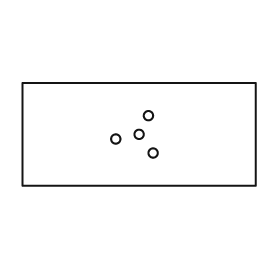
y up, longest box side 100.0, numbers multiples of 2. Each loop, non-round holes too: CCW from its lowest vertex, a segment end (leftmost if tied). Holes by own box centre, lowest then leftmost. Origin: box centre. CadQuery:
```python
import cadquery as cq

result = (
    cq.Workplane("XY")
    .moveTo(-50.0, -22.0)
    .lineTo(50.0, -22.0)
    .lineTo(50.0, 22.0)
    .lineTo(-50.0, 22.0)
    .close()
    .moveTo(6.0, -8.0)
    .circle(2.0)
    .moveTo(-10.0, -2.0)
    .circle(2.0)
    .moveTo(0.0, 0.0)
    .circle(2.0)
    .moveTo(4.0, 8.0)
    .circle(2.0)
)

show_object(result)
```